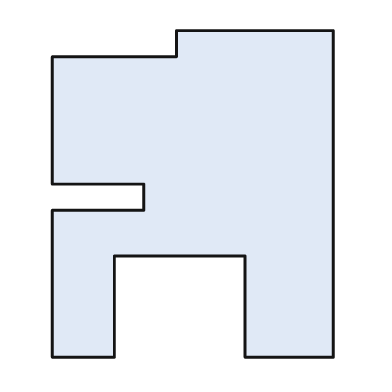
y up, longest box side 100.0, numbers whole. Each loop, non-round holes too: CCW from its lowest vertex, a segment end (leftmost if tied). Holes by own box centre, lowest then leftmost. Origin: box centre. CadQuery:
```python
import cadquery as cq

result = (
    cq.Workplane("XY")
    .moveTo(-43.0, -50.0)
    .lineTo(-24.0, -50.0)
    .lineTo(-24.0, -19.0)
    .lineTo(16.0, -19.0)
    .lineTo(16.0, -50.0)
    .lineTo(43.0, -50.0)
    .lineTo(43.0, 50.0)
    .lineTo(-5.0, 50.0)
    .lineTo(-5.0, 42.0)
    .lineTo(-43.0, 42.0)
    .lineTo(-43.0, 3.0)
    .lineTo(-15.0, 3.0)
    .lineTo(-15.0, -5.0)
    .lineTo(-43.0, -5.0)
    .close()
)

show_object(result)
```